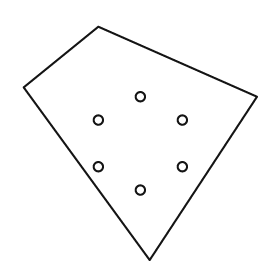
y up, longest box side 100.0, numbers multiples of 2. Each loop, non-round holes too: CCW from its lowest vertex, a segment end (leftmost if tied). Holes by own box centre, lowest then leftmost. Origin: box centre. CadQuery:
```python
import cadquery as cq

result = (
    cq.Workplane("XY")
    .moveTo(4.0, -50.0)
    .lineTo(50.0, 20.0)
    .lineTo(-18.0, 50.0)
    .lineTo(-50.0, 24.0)
    .close()
    .moveTo(0.0, -20.0)
    .circle(2.0)
    .moveTo(-18.0, -10.0)
    .circle(2.0)
    .moveTo(18.0, -10.0)
    .circle(2.0)
    .moveTo(-18.0, 10.0)
    .circle(2.0)
    .moveTo(18.0, 10.0)
    .circle(2.0)
    .moveTo(0.0, 20.0)
    .circle(2.0)
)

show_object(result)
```